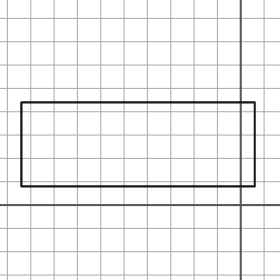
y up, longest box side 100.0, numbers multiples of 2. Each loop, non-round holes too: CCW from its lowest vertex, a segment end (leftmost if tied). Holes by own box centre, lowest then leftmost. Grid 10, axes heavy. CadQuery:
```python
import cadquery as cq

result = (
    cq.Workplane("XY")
    .moveTo(-94.0, 8.0)
    .lineTo(6.0, 8.0)
    .lineTo(6.0, 44.0)
    .lineTo(-94.0, 44.0)
    .close()
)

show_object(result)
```